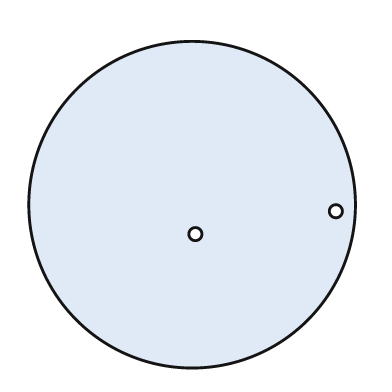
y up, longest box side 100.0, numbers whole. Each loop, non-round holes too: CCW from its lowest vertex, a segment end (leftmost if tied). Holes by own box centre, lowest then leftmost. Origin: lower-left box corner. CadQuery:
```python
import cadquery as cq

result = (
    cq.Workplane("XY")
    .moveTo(50.0, 50.0)
    .circle(50.0)
    .moveTo(51.0, 41.0)
    .circle(2.0)
    .moveTo(94.0, 48.0)
    .circle(2.0)
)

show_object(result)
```